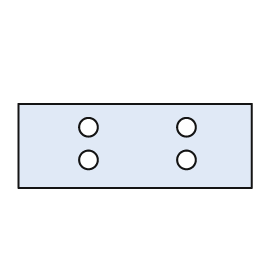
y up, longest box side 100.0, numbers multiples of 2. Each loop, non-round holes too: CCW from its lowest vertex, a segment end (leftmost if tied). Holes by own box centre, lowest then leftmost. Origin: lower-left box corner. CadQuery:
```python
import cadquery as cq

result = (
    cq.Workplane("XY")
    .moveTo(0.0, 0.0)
    .lineTo(100.0, 0.0)
    .lineTo(100.0, 36.0)
    .lineTo(0.0, 36.0)
    .close()
    .moveTo(30.0, 12.0)
    .circle(4.0)
    .moveTo(72.0, 12.0)
    .circle(4.0)
    .moveTo(30.0, 26.0)
    .circle(4.0)
    .moveTo(72.0, 26.0)
    .circle(4.0)
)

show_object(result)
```